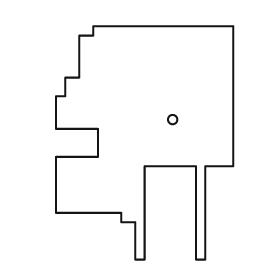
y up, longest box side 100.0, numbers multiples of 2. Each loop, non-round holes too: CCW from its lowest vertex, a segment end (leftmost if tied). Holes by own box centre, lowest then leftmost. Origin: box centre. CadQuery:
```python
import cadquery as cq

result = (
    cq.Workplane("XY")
    .moveTo(-4.0, -50.0)
    .lineTo(0.0, -50.0)
    .lineTo(0.0, -10.0)
    .lineTo(22.0, -10.0)
    .lineTo(22.0, -50.0)
    .lineTo(26.0, -50.0)
    .lineTo(26.0, -10.0)
    .lineTo(38.0, -10.0)
    .lineTo(38.0, 50.0)
    .lineTo(-22.0, 50.0)
    .lineTo(-22.0, 46.0)
    .lineTo(-28.0, 46.0)
    .lineTo(-28.0, 28.0)
    .lineTo(-34.0, 28.0)
    .lineTo(-34.0, 20.0)
    .lineTo(-38.0, 20.0)
    .lineTo(-38.0, 6.0)
    .lineTo(-20.0, 6.0)
    .lineTo(-20.0, -6.0)
    .lineTo(-38.0, -6.0)
    .lineTo(-38.0, -30.0)
    .lineTo(-10.0, -30.0)
    .lineTo(-10.0, -34.0)
    .lineTo(-4.0, -34.0)
    .close()
    .moveTo(12.0, 10.0)
    .circle(2.0)
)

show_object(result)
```